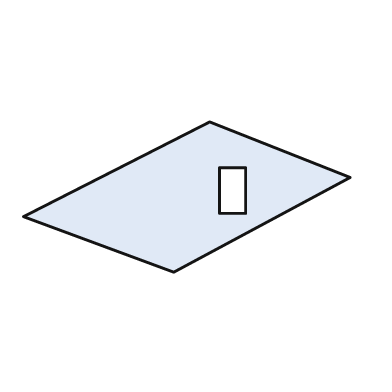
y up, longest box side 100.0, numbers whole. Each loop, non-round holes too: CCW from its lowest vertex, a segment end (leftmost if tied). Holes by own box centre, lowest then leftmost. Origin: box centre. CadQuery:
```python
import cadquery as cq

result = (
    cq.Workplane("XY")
    .moveTo(-4.0, -23.0)
    .lineTo(50.0, 6.0)
    .lineTo(7.0, 23.0)
    .lineTo(-50.0, -6.0)
    .close()
    .moveTo(10.0, -5.0)
    .lineTo(18.0, -5.0)
    .lineTo(18.0, 9.0)
    .lineTo(10.0, 9.0)
    .close()
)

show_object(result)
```